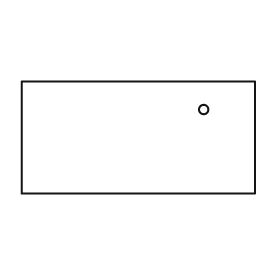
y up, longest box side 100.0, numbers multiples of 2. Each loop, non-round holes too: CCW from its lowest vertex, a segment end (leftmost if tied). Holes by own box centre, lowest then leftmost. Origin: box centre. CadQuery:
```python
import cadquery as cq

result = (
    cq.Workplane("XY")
    .moveTo(-50.0, -24.0)
    .lineTo(50.0, -24.0)
    .lineTo(50.0, 24.0)
    .lineTo(-50.0, 24.0)
    .close()
    .moveTo(28.0, 12.0)
    .circle(2.0)
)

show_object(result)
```